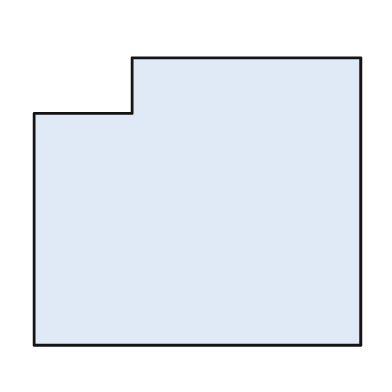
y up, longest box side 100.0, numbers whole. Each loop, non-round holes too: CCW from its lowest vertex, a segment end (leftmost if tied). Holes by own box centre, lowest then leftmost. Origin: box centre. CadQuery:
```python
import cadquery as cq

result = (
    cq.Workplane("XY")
    .moveTo(-50.0, -44.0)
    .lineTo(50.0, -44.0)
    .lineTo(50.0, 44.0)
    .lineTo(-20.0, 44.0)
    .lineTo(-20.0, 27.0)
    .lineTo(-50.0, 27.0)
    .close()
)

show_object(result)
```